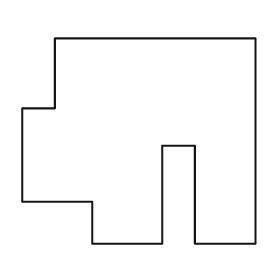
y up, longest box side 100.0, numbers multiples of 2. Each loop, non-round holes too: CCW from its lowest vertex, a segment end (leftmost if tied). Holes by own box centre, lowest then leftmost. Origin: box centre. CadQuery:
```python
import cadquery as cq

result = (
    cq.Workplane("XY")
    .moveTo(-20.0, -44.0)
    .lineTo(10.0, -44.0)
    .lineTo(10.0, -2.0)
    .lineTo(24.0, -2.0)
    .lineTo(24.0, -44.0)
    .lineTo(50.0, -44.0)
    .lineTo(50.0, 44.0)
    .lineTo(-36.0, 44.0)
    .lineTo(-36.0, 14.0)
    .lineTo(-50.0, 14.0)
    .lineTo(-50.0, -26.0)
    .lineTo(-20.0, -26.0)
    .close()
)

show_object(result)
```